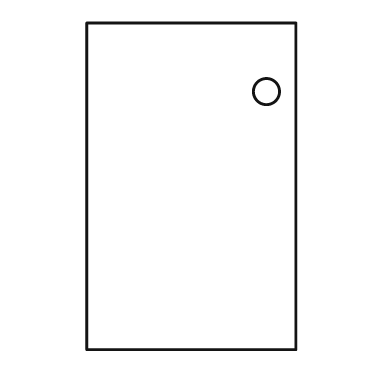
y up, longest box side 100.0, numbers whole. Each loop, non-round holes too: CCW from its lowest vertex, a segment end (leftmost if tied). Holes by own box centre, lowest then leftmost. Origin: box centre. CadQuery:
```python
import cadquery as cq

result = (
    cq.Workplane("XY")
    .moveTo(-32.0, -50.0)
    .lineTo(32.0, -50.0)
    .lineTo(32.0, 50.0)
    .lineTo(-32.0, 50.0)
    .close()
    .moveTo(23.0, 29.0)
    .circle(4.0)
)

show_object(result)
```